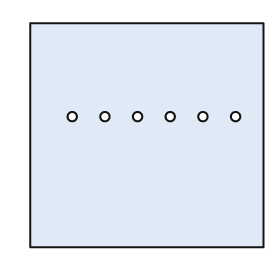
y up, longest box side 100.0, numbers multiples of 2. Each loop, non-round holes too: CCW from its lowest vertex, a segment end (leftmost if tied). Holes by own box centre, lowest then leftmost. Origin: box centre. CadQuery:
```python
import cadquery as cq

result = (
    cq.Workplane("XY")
    .moveTo(-50.0, -48.0)
    .lineTo(50.0, -48.0)
    .lineTo(50.0, 48.0)
    .lineTo(-50.0, 48.0)
    .close()
    .moveTo(-32.0, 8.0)
    .circle(2.0)
    .moveTo(-18.0, 8.0)
    .circle(2.0)
    .moveTo(-4.0, 8.0)
    .circle(2.0)
    .moveTo(10.0, 8.0)
    .circle(2.0)
    .moveTo(24.0, 8.0)
    .circle(2.0)
    .moveTo(38.0, 8.0)
    .circle(2.0)
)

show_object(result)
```